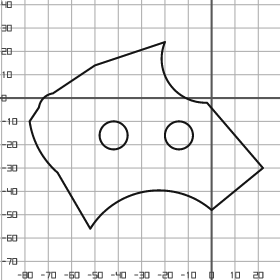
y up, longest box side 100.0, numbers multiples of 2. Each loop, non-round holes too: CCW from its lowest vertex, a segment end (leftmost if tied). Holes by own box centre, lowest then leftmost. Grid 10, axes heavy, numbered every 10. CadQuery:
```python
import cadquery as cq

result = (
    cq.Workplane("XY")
    .moveTo(-52.0, -56.0)
    .threePointArc((-28.0, -40.0), (0.0, -48.0))
    .lineTo(22.0, -30.0)
    .lineTo(-2.0, -2.0)
    .threePointArc((-18.0, 6.0), (-20.0, 24.0))
    .lineTo(-50.0, 14.0)
    .lineTo(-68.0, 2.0)
    .threePointArc((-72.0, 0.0), (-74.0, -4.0))
    .lineTo(-78.0, -10.0)
    .threePointArc((-74.0, -22.0), (-66.0, -32.0))
    .close()
    .moveTo(-42.0, -16.0)
    .circle(6.0)
    .moveTo(-14.0, -16.0)
    .circle(6.0)
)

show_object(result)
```